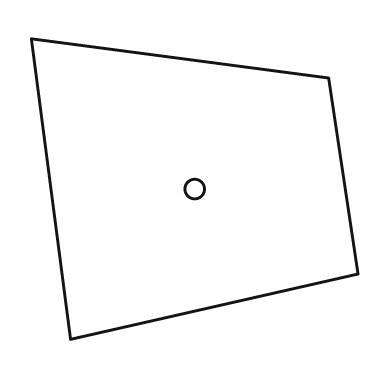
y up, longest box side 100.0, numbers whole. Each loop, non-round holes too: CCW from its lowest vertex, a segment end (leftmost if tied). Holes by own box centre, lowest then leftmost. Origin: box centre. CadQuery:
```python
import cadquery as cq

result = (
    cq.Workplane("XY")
    .moveTo(-38.0, -46.0)
    .lineTo(50.0, -26.0)
    .lineTo(41.0, 34.0)
    .lineTo(-50.0, 46.0)
    .close()
    .moveTo(0.0, 0.0)
    .circle(3.0)
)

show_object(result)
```